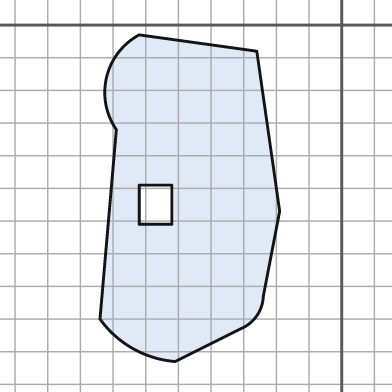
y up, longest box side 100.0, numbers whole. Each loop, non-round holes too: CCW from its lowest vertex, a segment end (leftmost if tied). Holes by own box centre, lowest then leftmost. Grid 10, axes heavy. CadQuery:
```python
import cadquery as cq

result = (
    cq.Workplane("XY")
    .moveTo(-51.0, -103.0)
    .lineTo(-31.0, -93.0)
    .threePointArc((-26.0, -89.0), (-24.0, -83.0))
    .lineTo(-19.0, -57.0)
    .lineTo(-26.0, -8.0)
    .lineTo(-62.0, -3.0)
    .threePointArc((-72.0, -16.0), (-69.0, -32.0))
    .lineTo(-74.0, -90.0)
    .threePointArc((-64.0, -99.0), (-51.0, -103.0))
    .close()
    .moveTo(-62.0, -61.0)
    .lineTo(-52.0, -61.0)
    .lineTo(-52.0, -49.0)
    .lineTo(-62.0, -49.0)
    .close()
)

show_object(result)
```